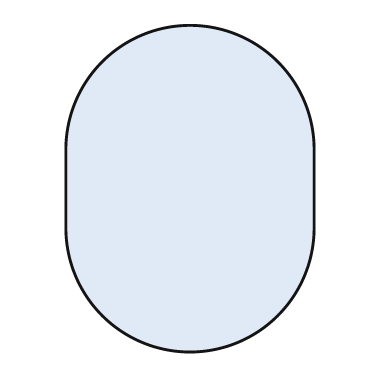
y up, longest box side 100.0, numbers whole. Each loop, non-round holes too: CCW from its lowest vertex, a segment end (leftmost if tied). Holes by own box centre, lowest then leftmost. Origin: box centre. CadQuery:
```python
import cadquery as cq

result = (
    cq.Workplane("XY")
    .moveTo(-38.0, -12.0)
    .threePointArc((0.0, -50.0), (38.0, -12.0))
    .lineTo(38.0, 12.0)
    .threePointArc((0.0, 50.0), (-38.0, 12.0))
    .close()
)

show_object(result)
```